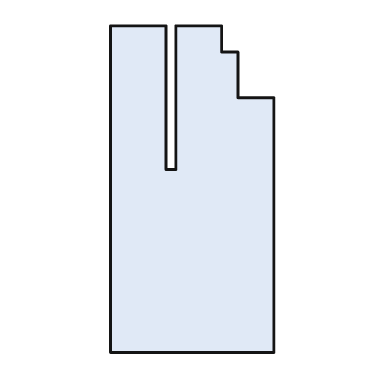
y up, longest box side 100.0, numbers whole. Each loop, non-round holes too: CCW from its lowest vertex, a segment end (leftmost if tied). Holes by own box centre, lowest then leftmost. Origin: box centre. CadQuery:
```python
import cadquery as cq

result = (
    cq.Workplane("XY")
    .moveTo(-25.0, -50.0)
    .lineTo(25.0, -50.0)
    .lineTo(25.0, 28.0)
    .lineTo(14.0, 28.0)
    .lineTo(14.0, 42.0)
    .lineTo(9.0, 42.0)
    .lineTo(9.0, 50.0)
    .lineTo(-5.0, 50.0)
    .lineTo(-5.0, 6.0)
    .lineTo(-8.0, 6.0)
    .lineTo(-8.0, 50.0)
    .lineTo(-25.0, 50.0)
    .close()
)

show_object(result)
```